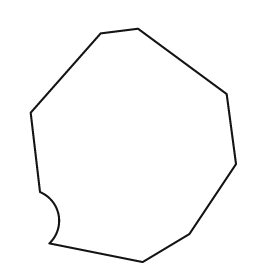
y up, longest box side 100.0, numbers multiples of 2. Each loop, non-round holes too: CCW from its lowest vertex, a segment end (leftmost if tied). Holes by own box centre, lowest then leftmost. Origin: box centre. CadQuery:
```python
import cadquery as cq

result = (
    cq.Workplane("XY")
    .moveTo(4.0, -50.0)
    .lineTo(24.0, -38.0)
    .lineTo(44.0, -8.0)
    .lineTo(40.0, 22.0)
    .lineTo(2.0, 50.0)
    .lineTo(-14.0, 48.0)
    .lineTo(-44.0, 14.0)
    .lineTo(-40.0, -20.0)
    .threePointArc((-32.0, -30.0), (-36.0, -42.0))
    .close()
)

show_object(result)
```